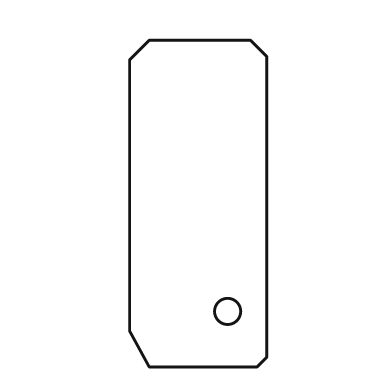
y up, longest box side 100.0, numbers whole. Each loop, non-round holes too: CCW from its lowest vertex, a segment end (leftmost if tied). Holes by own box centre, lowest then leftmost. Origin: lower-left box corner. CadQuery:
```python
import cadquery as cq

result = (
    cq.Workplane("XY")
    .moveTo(6.0, 0.0)
    .lineTo(39.0, 0.0)
    .lineTo(42.0, 3.0)
    .lineTo(42.0, 95.0)
    .lineTo(37.0, 100.0)
    .lineTo(6.0, 100.0)
    .lineTo(0.0, 94.0)
    .lineTo(0.0, 11.0)
    .close()
    .moveTo(30.0, 17.0)
    .circle(4.0)
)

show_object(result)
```